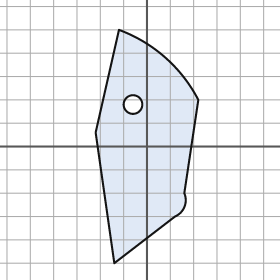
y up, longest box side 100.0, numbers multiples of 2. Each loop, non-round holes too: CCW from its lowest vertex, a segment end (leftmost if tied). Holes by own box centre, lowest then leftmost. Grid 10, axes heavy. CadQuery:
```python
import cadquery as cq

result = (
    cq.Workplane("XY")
    .moveTo(-14.0, -50.0)
    .lineTo(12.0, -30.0)
    .threePointArc((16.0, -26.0), (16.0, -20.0))
    .lineTo(22.0, 20.0)
    .threePointArc((8.0, 38.0), (-12.0, 50.0))
    .lineTo(-22.0, 6.0)
    .close()
    .moveTo(-6.0, 18.0)
    .circle(4.0)
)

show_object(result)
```